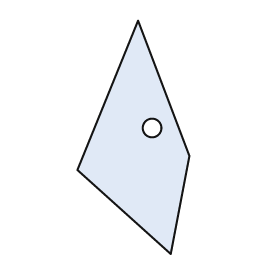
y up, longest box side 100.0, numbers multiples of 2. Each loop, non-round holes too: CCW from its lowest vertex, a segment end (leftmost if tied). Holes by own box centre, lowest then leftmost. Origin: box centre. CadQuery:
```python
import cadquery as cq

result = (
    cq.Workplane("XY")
    .moveTo(16.0, -50.0)
    .lineTo(24.0, -8.0)
    .lineTo(2.0, 50.0)
    .lineTo(-24.0, -14.0)
    .close()
    .moveTo(8.0, 4.0)
    .circle(4.0)
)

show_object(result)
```